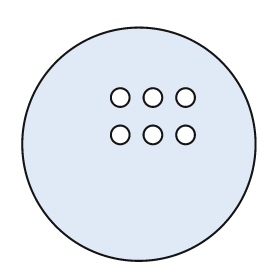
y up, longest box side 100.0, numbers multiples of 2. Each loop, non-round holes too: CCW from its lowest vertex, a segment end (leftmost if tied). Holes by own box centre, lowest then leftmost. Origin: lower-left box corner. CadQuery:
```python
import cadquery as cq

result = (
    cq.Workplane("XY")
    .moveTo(50.0, 50.0)
    .circle(50.0)
    .moveTo(42.0, 54.0)
    .circle(4.0)
    .moveTo(56.0, 54.0)
    .circle(4.0)
    .moveTo(70.0, 54.0)
    .circle(4.0)
    .moveTo(42.0, 70.0)
    .circle(4.0)
    .moveTo(56.0, 70.0)
    .circle(4.0)
    .moveTo(70.0, 70.0)
    .circle(4.0)
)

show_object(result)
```